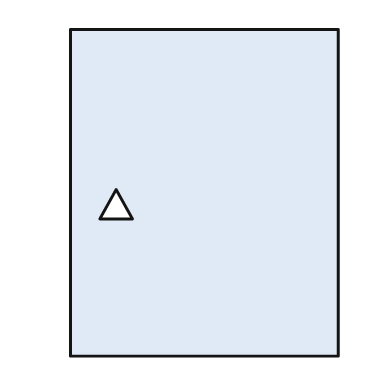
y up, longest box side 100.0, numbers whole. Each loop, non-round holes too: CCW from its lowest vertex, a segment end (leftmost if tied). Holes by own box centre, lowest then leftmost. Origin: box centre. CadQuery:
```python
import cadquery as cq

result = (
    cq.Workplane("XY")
    .moveTo(-41.0, -50.0)
    .lineTo(41.0, -50.0)
    .lineTo(41.0, 50.0)
    .lineTo(-41.0, 50.0)
    .close()
    .moveTo(-32.0, -8.0)
    .lineTo(-22.0, -8.0)
    .lineTo(-27.0, 1.0)
    .close()
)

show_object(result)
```